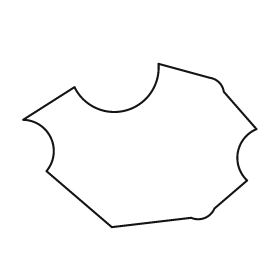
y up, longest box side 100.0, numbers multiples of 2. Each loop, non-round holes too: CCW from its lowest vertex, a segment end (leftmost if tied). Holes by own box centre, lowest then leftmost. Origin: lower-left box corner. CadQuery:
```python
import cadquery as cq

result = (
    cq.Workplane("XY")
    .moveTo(38.0, 0.0)
    .lineTo(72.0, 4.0)
    .threePointArc((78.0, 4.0), (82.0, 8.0))
    .lineTo(96.0, 20.0)
    .threePointArc((92.0, 32.0), (100.0, 42.0))
    .lineTo(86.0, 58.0)
    .threePointArc((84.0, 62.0), (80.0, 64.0))
    .lineTo(58.0, 70.0)
    .threePointArc((44.0, 50.0), (22.0, 60.0))
    .lineTo(0.0, 46.0)
    .threePointArc((12.0, 38.0), (10.0, 24.0))
    .close()
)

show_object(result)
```